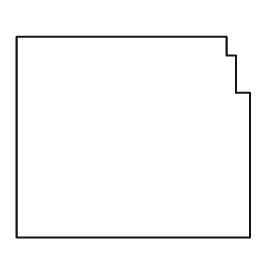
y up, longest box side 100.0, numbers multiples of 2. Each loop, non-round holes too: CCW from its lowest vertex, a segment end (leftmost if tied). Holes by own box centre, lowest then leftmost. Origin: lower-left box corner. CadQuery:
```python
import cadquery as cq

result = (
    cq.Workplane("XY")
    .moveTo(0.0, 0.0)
    .lineTo(100.0, 0.0)
    .lineTo(100.0, 62.0)
    .lineTo(94.0, 62.0)
    .lineTo(94.0, 78.0)
    .lineTo(90.0, 78.0)
    .lineTo(90.0, 86.0)
    .lineTo(0.0, 86.0)
    .close()
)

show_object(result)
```